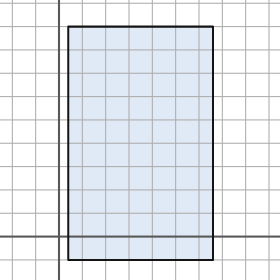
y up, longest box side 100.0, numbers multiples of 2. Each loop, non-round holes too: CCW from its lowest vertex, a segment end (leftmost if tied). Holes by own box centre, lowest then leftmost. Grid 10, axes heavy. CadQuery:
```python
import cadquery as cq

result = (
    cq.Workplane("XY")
    .moveTo(4.0, -10.0)
    .lineTo(66.0, -10.0)
    .lineTo(66.0, 90.0)
    .lineTo(4.0, 90.0)
    .close()
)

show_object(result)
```